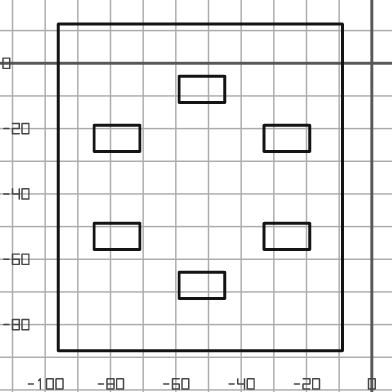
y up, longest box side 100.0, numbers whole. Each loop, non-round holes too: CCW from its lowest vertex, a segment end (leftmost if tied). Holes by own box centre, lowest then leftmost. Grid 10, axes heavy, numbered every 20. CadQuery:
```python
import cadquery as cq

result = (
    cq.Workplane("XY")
    .moveTo(-96.0, -88.0)
    .lineTo(-9.0, -88.0)
    .lineTo(-9.0, 12.0)
    .lineTo(-96.0, 12.0)
    .close()
    .moveTo(-59.0, -72.0)
    .lineTo(-45.0, -72.0)
    .lineTo(-45.0, -64.0)
    .lineTo(-59.0, -64.0)
    .close()
    .moveTo(-85.0, -57.0)
    .lineTo(-71.0, -57.0)
    .lineTo(-71.0, -49.0)
    .lineTo(-85.0, -49.0)
    .close()
    .moveTo(-33.0, -57.0)
    .lineTo(-19.0, -57.0)
    .lineTo(-19.0, -49.0)
    .lineTo(-33.0, -49.0)
    .close()
    .moveTo(-85.0, -27.0)
    .lineTo(-71.0, -27.0)
    .lineTo(-71.0, -19.0)
    .lineTo(-85.0, -19.0)
    .close()
    .moveTo(-33.0, -27.0)
    .lineTo(-19.0, -27.0)
    .lineTo(-19.0, -19.0)
    .lineTo(-33.0, -19.0)
    .close()
    .moveTo(-59.0, -12.0)
    .lineTo(-45.0, -12.0)
    .lineTo(-45.0, -4.0)
    .lineTo(-59.0, -4.0)
    .close()
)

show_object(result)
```